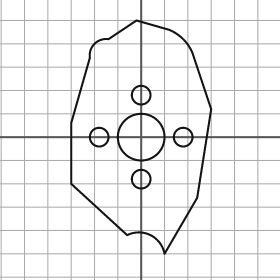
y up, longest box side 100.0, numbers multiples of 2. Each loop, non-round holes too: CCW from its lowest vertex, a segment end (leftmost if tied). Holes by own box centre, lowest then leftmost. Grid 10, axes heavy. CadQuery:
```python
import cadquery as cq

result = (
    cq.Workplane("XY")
    .moveTo(10.0, -50.0)
    .lineTo(24.0, -26.0)
    .lineTo(30.0, 12.0)
    .lineTo(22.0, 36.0)
    .threePointArc((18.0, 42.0), (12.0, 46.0))
    .lineTo(-2.0, 50.0)
    .lineTo(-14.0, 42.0)
    .threePointArc((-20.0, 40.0), (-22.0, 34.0))
    .lineTo(-30.0, 6.0)
    .lineTo(-30.0, -20.0)
    .lineTo(-6.0, -42.0)
    .threePointArc((4.0, -42.0), (10.0, -50.0))
    .close()
    .moveTo(0.0, -18.0)
    .circle(4.0)
    .moveTo(-18.0, 0.0)
    .circle(4.0)
    .moveTo(0.0, 0.0)
    .circle(10.0)
    .moveTo(18.0, 0.0)
    .circle(4.0)
    .moveTo(0.0, 18.0)
    .circle(4.0)
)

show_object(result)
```